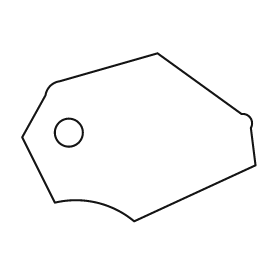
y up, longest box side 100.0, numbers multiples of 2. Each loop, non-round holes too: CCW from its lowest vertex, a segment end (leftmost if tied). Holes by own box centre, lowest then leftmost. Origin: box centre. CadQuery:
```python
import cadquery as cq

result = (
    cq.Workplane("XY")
    .moveTo(-2.0, -36.0)
    .lineTo(50.0, -12.0)
    .lineTo(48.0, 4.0)
    .threePointArc((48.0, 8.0), (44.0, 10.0))
    .lineTo(8.0, 36.0)
    .lineTo(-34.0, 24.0)
    .threePointArc((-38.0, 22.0), (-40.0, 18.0))
    .lineTo(-50.0, 0.0)
    .lineTo(-36.0, -28.0)
    .threePointArc((-18.0, -28.0), (-2.0, -36.0))
    .close()
    .moveTo(-30.0, 2.0)
    .circle(6.0)
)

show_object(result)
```